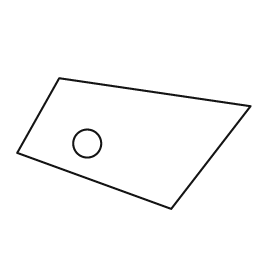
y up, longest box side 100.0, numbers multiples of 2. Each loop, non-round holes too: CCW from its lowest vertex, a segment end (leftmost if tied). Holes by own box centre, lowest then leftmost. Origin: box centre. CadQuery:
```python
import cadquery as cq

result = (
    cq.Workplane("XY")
    .moveTo(16.0, -28.0)
    .lineTo(50.0, 16.0)
    .lineTo(-32.0, 28.0)
    .lineTo(-50.0, -4.0)
    .close()
    .moveTo(-20.0, 0.0)
    .circle(6.0)
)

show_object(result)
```